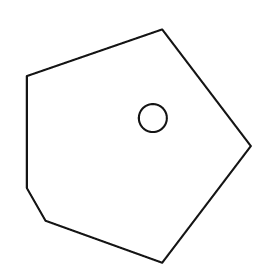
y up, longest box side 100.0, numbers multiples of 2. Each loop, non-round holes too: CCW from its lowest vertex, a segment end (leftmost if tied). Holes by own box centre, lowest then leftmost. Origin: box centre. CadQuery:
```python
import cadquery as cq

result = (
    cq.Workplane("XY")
    .moveTo(10.0, -50.0)
    .lineTo(48.0, 0.0)
    .lineTo(10.0, 50.0)
    .lineTo(-48.0, 30.0)
    .lineTo(-48.0, -18.0)
    .lineTo(-40.0, -32.0)
    .close()
    .moveTo(6.0, 12.0)
    .circle(6.0)
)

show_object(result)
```